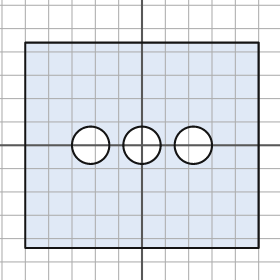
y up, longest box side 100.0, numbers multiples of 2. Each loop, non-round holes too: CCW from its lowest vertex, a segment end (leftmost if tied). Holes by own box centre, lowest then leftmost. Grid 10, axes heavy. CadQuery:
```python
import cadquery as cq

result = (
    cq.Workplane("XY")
    .moveTo(-50.0, -44.0)
    .lineTo(50.0, -44.0)
    .lineTo(50.0, 44.0)
    .lineTo(-50.0, 44.0)
    .close()
    .moveTo(-22.0, 0.0)
    .circle(8.0)
    .moveTo(0.0, 0.0)
    .circle(8.0)
    .moveTo(22.0, 0.0)
    .circle(8.0)
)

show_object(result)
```